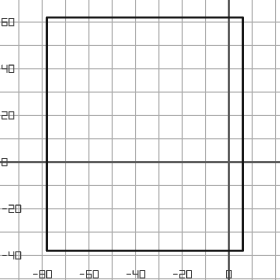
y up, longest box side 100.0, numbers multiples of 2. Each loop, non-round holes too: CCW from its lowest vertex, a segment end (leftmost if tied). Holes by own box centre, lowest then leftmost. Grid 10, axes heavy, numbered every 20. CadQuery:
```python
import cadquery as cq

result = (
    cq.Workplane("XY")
    .moveTo(-78.0, -38.0)
    .lineTo(6.0, -38.0)
    .lineTo(6.0, 62.0)
    .lineTo(-78.0, 62.0)
    .close()
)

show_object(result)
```